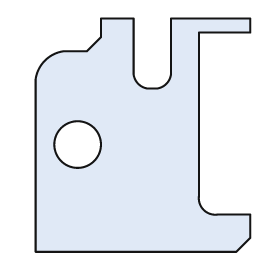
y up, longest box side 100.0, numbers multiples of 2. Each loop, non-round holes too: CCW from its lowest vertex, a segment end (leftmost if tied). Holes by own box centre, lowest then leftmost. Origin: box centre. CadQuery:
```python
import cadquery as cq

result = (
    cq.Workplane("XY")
    .moveTo(-46.0, -50.0)
    .lineTo(40.0, -50.0)
    .lineTo(46.0, -44.0)
    .lineTo(46.0, -34.0)
    .lineTo(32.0, -34.0)
    .threePointArc((26.0, -32.0), (24.0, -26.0))
    .lineTo(24.0, 44.0)
    .lineTo(46.0, 44.0)
    .lineTo(46.0, 50.0)
    .lineTo(12.0, 50.0)
    .lineTo(12.0, 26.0)
    .threePointArc((10.0, 22.0), (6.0, 20.0))
    .lineTo(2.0, 20.0)
    .threePointArc((-2.0, 22.0), (-4.0, 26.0))
    .lineTo(-4.0, 50.0)
    .lineTo(-18.0, 50.0)
    .lineTo(-18.0, 42.0)
    .lineTo(-24.0, 36.0)
    .lineTo(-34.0, 36.0)
    .threePointArc((-42.0, 32.0), (-46.0, 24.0))
    .close()
    .moveTo(-28.0, -4.0)
    .circle(10.0)
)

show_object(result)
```